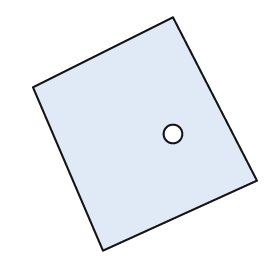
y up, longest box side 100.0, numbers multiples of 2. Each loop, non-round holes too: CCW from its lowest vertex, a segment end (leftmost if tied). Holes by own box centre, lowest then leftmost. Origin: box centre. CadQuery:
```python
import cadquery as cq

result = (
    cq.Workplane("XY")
    .moveTo(-18.0, -50.0)
    .lineTo(48.0, -20.0)
    .lineTo(12.0, 50.0)
    .lineTo(-48.0, 20.0)
    .close()
    .moveTo(12.0, 0.0)
    .circle(4.0)
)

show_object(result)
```